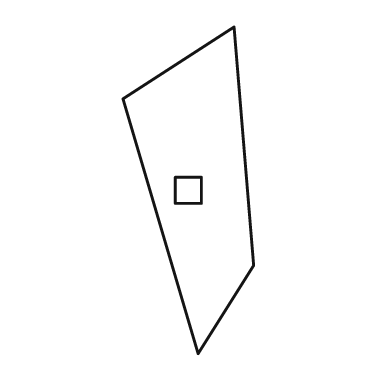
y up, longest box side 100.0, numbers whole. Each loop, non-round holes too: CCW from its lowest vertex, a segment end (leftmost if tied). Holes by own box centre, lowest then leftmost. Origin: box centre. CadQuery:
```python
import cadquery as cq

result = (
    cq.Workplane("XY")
    .moveTo(3.0, -50.0)
    .lineTo(20.0, -23.0)
    .lineTo(14.0, 50.0)
    .lineTo(-20.0, 28.0)
    .close()
    .moveTo(-4.0, -4.0)
    .lineTo(4.0, -4.0)
    .lineTo(4.0, 4.0)
    .lineTo(-4.0, 4.0)
    .close()
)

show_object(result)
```